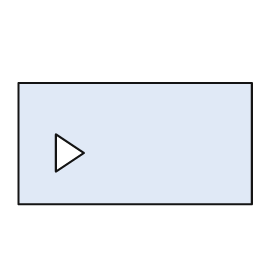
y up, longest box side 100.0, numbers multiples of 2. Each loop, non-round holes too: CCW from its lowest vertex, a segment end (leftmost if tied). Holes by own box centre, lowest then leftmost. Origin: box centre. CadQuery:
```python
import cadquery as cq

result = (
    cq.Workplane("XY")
    .moveTo(-50.0, -26.0)
    .lineTo(50.0, -26.0)
    .lineTo(50.0, 26.0)
    .lineTo(-50.0, 26.0)
    .close()
    .moveTo(-34.0, -12.0)
    .lineTo(-22.0, -4.0)
    .lineTo(-34.0, 4.0)
    .close()
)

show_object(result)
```